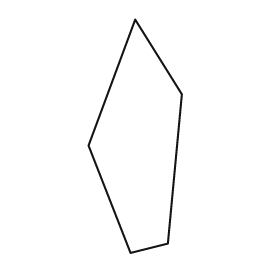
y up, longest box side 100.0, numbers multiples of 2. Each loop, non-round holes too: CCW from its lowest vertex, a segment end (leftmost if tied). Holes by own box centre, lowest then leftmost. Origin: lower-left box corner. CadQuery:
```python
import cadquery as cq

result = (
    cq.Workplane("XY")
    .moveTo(18.0, 0.0)
    .lineTo(34.0, 4.0)
    .lineTo(40.0, 68.0)
    .lineTo(20.0, 100.0)
    .lineTo(0.0, 46.0)
    .close()
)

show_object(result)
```